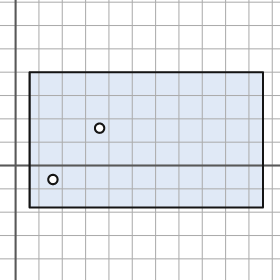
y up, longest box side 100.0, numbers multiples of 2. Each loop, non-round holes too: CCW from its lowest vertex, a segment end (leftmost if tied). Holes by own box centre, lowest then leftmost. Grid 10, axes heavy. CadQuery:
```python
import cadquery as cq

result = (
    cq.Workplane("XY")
    .moveTo(6.0, -18.0)
    .lineTo(106.0, -18.0)
    .lineTo(106.0, 40.0)
    .lineTo(6.0, 40.0)
    .close()
    .moveTo(16.0, -6.0)
    .circle(2.0)
    .moveTo(36.0, 16.0)
    .circle(2.0)
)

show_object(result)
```